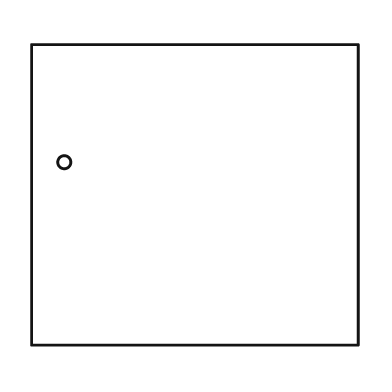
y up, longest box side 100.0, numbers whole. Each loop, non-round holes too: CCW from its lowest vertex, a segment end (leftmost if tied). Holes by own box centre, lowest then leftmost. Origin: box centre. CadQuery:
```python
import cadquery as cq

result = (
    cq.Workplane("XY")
    .moveTo(-50.0, -46.0)
    .lineTo(50.0, -46.0)
    .lineTo(50.0, 46.0)
    .lineTo(-50.0, 46.0)
    .close()
    .moveTo(-40.0, 10.0)
    .circle(2.0)
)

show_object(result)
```